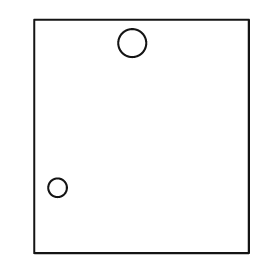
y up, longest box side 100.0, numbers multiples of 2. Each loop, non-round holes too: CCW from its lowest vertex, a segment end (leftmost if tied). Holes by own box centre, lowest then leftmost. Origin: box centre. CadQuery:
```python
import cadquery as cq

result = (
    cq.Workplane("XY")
    .moveTo(-46.0, -50.0)
    .lineTo(46.0, -50.0)
    .lineTo(46.0, 50.0)
    .lineTo(-46.0, 50.0)
    .close()
    .moveTo(-36.0, -22.0)
    .circle(4.0)
    .moveTo(-4.0, 40.0)
    .circle(6.0)
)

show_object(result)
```